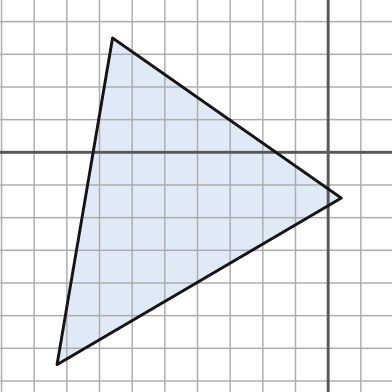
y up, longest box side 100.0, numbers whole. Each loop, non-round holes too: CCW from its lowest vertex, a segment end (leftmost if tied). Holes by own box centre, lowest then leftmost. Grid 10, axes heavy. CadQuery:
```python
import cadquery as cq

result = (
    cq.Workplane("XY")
    .moveTo(-83.0, -65.0)
    .lineTo(4.0, -14.0)
    .lineTo(-66.0, 35.0)
    .close()
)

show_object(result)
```